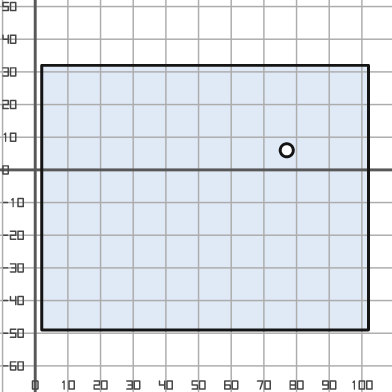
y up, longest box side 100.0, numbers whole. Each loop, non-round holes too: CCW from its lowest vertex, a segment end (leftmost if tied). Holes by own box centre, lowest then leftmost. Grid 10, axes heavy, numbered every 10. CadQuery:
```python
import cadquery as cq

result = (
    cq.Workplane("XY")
    .moveTo(2.0, -49.0)
    .lineTo(102.0, -49.0)
    .lineTo(102.0, 32.0)
    .lineTo(2.0, 32.0)
    .close()
    .moveTo(77.0, 6.0)
    .circle(2.0)
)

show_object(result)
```